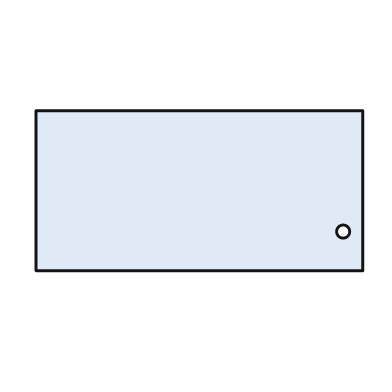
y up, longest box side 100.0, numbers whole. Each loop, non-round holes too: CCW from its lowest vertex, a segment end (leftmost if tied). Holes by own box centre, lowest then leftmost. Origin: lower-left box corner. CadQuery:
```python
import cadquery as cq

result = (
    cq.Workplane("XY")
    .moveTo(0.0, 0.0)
    .lineTo(100.0, 0.0)
    .lineTo(100.0, 49.0)
    .lineTo(0.0, 49.0)
    .close()
    .moveTo(94.0, 12.0)
    .circle(2.0)
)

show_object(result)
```